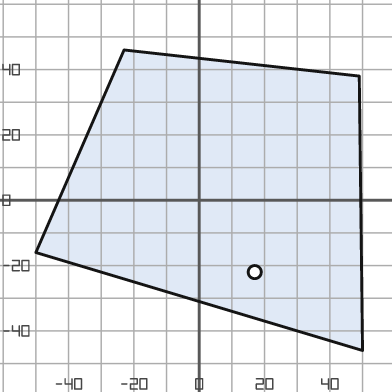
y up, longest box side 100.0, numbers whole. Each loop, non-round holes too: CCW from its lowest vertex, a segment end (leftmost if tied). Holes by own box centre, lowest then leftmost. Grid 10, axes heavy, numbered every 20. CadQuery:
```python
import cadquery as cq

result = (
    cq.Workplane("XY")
    .moveTo(50.0, -46.0)
    .lineTo(49.0, 38.0)
    .lineTo(-23.0, 46.0)
    .lineTo(-50.0, -16.0)
    .close()
    .moveTo(17.0, -22.0)
    .circle(2.0)
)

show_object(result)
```